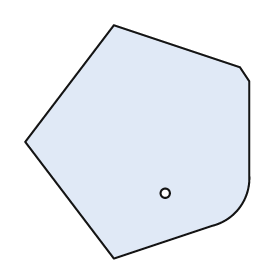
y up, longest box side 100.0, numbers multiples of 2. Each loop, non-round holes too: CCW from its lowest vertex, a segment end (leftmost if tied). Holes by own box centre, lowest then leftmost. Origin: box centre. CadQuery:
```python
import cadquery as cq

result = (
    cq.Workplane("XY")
    .moveTo(-10.0, -50.0)
    .lineTo(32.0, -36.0)
    .threePointArc((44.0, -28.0), (48.0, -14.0))
    .lineTo(48.0, 26.0)
    .lineTo(44.0, 32.0)
    .lineTo(-10.0, 50.0)
    .lineTo(-48.0, 0.0)
    .close()
    .moveTo(12.0, -22.0)
    .circle(2.0)
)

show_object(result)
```